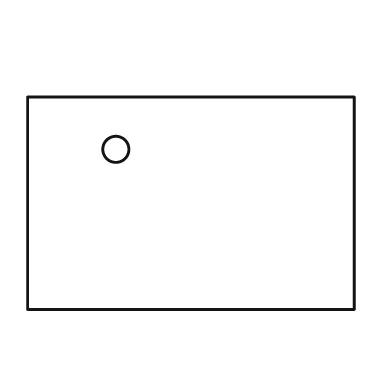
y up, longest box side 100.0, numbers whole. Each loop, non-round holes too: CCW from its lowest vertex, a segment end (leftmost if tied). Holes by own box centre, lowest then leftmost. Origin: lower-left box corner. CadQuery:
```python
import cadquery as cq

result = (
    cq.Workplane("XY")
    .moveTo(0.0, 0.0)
    .lineTo(100.0, 0.0)
    .lineTo(100.0, 65.0)
    .lineTo(0.0, 65.0)
    .close()
    .moveTo(27.0, 49.0)
    .circle(4.0)
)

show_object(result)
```